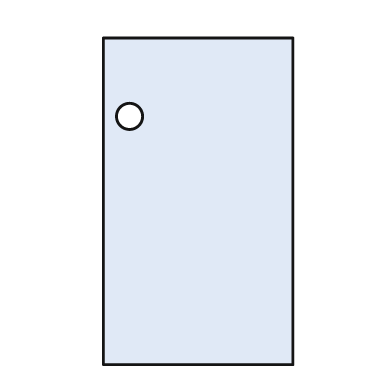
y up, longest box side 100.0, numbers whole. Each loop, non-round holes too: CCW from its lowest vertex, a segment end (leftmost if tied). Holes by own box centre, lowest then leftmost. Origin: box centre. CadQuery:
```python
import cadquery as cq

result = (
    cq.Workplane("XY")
    .moveTo(-29.0, -50.0)
    .lineTo(29.0, -50.0)
    .lineTo(29.0, 50.0)
    .lineTo(-29.0, 50.0)
    .close()
    .moveTo(-21.0, 26.0)
    .circle(4.0)
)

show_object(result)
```